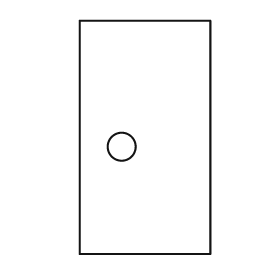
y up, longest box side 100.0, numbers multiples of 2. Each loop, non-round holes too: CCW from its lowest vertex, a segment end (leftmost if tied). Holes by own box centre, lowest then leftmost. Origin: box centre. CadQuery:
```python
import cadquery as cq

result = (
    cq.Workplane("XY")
    .moveTo(-28.0, -50.0)
    .lineTo(28.0, -50.0)
    .lineTo(28.0, 50.0)
    .lineTo(-28.0, 50.0)
    .close()
    .moveTo(-10.0, -4.0)
    .circle(6.0)
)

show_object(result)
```